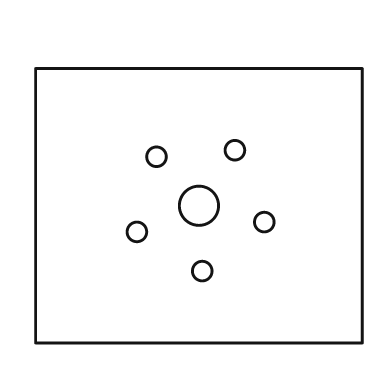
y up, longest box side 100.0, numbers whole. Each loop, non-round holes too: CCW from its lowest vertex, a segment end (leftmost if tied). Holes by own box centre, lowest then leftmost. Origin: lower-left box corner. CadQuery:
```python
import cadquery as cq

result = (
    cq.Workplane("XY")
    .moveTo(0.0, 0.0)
    .lineTo(100.0, 0.0)
    .lineTo(100.0, 84.0)
    .lineTo(0.0, 84.0)
    .close()
    .moveTo(51.0, 22.0)
    .circle(3.0)
    .moveTo(31.0, 34.0)
    .circle(3.0)
    .moveTo(70.0, 37.0)
    .circle(3.0)
    .moveTo(50.0, 42.0)
    .circle(6.0)
    .moveTo(37.0, 57.0)
    .circle(3.0)
    .moveTo(61.0, 59.0)
    .circle(3.0)
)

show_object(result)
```